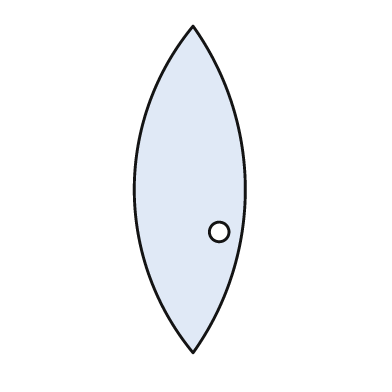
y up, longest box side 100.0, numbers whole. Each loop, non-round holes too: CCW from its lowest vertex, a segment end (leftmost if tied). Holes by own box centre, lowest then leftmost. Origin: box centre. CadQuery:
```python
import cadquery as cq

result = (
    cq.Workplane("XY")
    .moveTo(1.0, -50.0)
    .threePointArc((17.0, 0.0), (1.0, 50.0))
    .threePointArc((-17.0, 0.0), (1.0, -50.0))
    .close()
    .moveTo(9.0, -13.0)
    .circle(3.0)
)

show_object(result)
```